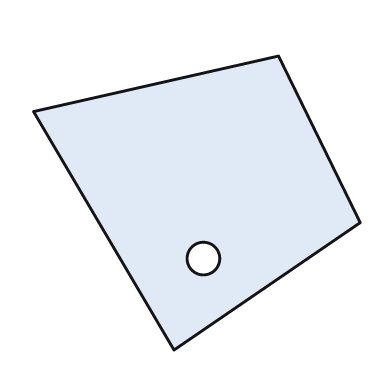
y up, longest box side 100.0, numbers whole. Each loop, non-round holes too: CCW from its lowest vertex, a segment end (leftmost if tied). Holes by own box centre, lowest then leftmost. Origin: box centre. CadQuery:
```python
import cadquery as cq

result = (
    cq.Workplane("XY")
    .moveTo(-7.0, -45.0)
    .lineTo(50.0, -6.0)
    .lineTo(25.0, 45.0)
    .lineTo(-50.0, 28.0)
    .close()
    .moveTo(2.0, -17.0)
    .circle(5.0)
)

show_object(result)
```